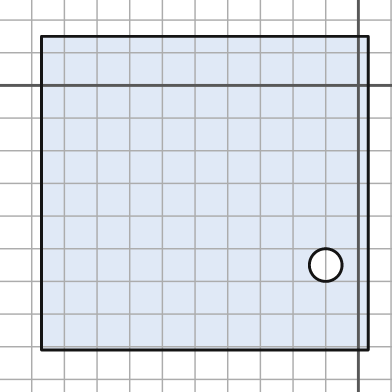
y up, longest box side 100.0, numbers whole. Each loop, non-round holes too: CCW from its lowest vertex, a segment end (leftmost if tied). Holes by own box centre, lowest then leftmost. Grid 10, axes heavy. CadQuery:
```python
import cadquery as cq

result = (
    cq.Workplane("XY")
    .moveTo(-97.0, -81.0)
    .lineTo(3.0, -81.0)
    .lineTo(3.0, 15.0)
    .lineTo(-97.0, 15.0)
    .close()
    .moveTo(-10.0, -55.0)
    .circle(5.0)
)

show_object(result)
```